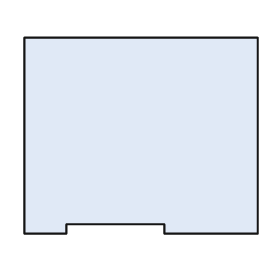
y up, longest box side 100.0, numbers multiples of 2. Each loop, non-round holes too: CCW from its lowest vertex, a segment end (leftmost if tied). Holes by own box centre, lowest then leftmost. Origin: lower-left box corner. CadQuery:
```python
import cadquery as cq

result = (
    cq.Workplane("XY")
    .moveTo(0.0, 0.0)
    .lineTo(18.0, 0.0)
    .lineTo(18.0, 4.0)
    .lineTo(60.0, 4.0)
    .lineTo(60.0, 0.0)
    .lineTo(100.0, 0.0)
    .lineTo(100.0, 84.0)
    .lineTo(0.0, 84.0)
    .close()
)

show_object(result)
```